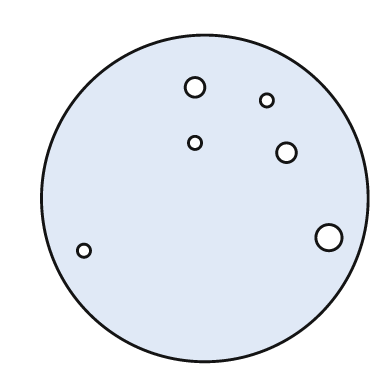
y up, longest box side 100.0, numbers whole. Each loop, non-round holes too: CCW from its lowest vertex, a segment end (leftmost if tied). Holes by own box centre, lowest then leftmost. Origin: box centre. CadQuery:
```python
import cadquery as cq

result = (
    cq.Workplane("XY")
    .moveTo(0.0, 0.0)
    .circle(50.0)
    .moveTo(-37.0, -16.0)
    .circle(2.0)
    .moveTo(38.0, -12.0)
    .circle(4.0)
    .moveTo(25.0, 14.0)
    .circle(3.0)
    .moveTo(-3.0, 17.0)
    .circle(2.0)
    .moveTo(19.0, 30.0)
    .circle(2.0)
    .moveTo(-3.0, 34.0)
    .circle(3.0)
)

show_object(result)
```